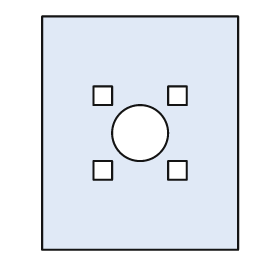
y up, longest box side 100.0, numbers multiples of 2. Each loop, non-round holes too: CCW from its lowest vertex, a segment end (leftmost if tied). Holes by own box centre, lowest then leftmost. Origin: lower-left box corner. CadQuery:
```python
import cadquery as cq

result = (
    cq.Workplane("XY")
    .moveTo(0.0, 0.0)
    .lineTo(84.0, 0.0)
    .lineTo(84.0, 100.0)
    .lineTo(0.0, 100.0)
    .close()
    .moveTo(22.0, 30.0)
    .lineTo(30.0, 30.0)
    .lineTo(30.0, 38.0)
    .lineTo(22.0, 38.0)
    .close()
    .moveTo(54.0, 30.0)
    .lineTo(62.0, 30.0)
    .lineTo(62.0, 38.0)
    .lineTo(54.0, 38.0)
    .close()
    .moveTo(42.0, 50.0)
    .circle(12.0)
    .moveTo(22.0, 62.0)
    .lineTo(30.0, 62.0)
    .lineTo(30.0, 70.0)
    .lineTo(22.0, 70.0)
    .close()
    .moveTo(54.0, 62.0)
    .lineTo(62.0, 62.0)
    .lineTo(62.0, 70.0)
    .lineTo(54.0, 70.0)
    .close()
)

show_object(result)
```